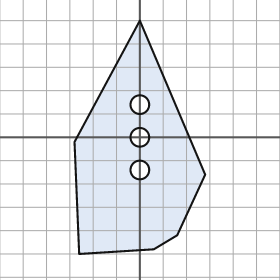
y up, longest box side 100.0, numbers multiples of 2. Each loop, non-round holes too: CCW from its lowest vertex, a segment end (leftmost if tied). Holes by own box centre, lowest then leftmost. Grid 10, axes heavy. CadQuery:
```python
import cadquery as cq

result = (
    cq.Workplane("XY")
    .moveTo(-26.0, -50.0)
    .lineTo(6.0, -48.0)
    .lineTo(16.0, -42.0)
    .lineTo(28.0, -16.0)
    .lineTo(0.0, 50.0)
    .lineTo(-28.0, -2.0)
    .close()
    .moveTo(0.0, -14.0)
    .circle(4.0)
    .moveTo(0.0, 0.0)
    .circle(4.0)
    .moveTo(0.0, 14.0)
    .circle(4.0)
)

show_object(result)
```